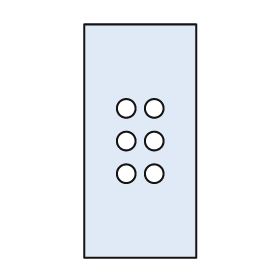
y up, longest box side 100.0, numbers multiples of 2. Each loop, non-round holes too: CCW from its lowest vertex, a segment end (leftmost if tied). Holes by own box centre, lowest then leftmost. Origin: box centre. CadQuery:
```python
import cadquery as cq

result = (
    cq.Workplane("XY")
    .moveTo(-24.0, -50.0)
    .lineTo(24.0, -50.0)
    .lineTo(24.0, 50.0)
    .lineTo(-24.0, 50.0)
    .close()
    .moveTo(-6.0, -14.0)
    .circle(4.0)
    .moveTo(6.0, -14.0)
    .circle(4.0)
    .moveTo(-6.0, 0.0)
    .circle(4.0)
    .moveTo(6.0, 0.0)
    .circle(4.0)
    .moveTo(-6.0, 14.0)
    .circle(4.0)
    .moveTo(6.0, 14.0)
    .circle(4.0)
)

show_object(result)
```